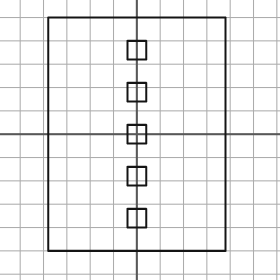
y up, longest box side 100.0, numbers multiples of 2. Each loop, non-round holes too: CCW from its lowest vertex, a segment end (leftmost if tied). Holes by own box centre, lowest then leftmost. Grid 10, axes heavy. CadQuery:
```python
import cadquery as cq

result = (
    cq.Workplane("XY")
    .moveTo(-38.0, -50.0)
    .lineTo(38.0, -50.0)
    .lineTo(38.0, 50.0)
    .lineTo(-38.0, 50.0)
    .close()
    .moveTo(-4.0, -40.0)
    .lineTo(4.0, -40.0)
    .lineTo(4.0, -32.0)
    .lineTo(-4.0, -32.0)
    .close()
    .moveTo(-4.0, -22.0)
    .lineTo(4.0, -22.0)
    .lineTo(4.0, -14.0)
    .lineTo(-4.0, -14.0)
    .close()
    .moveTo(-4.0, -4.0)
    .lineTo(4.0, -4.0)
    .lineTo(4.0, 4.0)
    .lineTo(-4.0, 4.0)
    .close()
    .moveTo(-4.0, 14.0)
    .lineTo(4.0, 14.0)
    .lineTo(4.0, 22.0)
    .lineTo(-4.0, 22.0)
    .close()
    .moveTo(-4.0, 32.0)
    .lineTo(4.0, 32.0)
    .lineTo(4.0, 40.0)
    .lineTo(-4.0, 40.0)
    .close()
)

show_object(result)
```